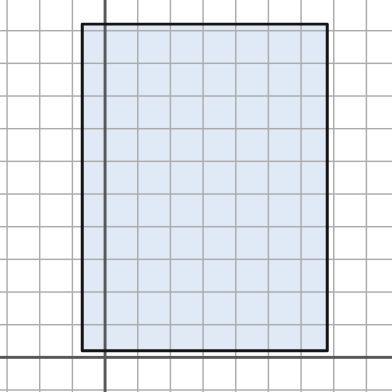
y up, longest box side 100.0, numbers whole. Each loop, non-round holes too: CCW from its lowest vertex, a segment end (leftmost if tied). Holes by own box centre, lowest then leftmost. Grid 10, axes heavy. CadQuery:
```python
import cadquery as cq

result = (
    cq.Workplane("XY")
    .moveTo(-7.0, 2.0)
    .lineTo(68.0, 2.0)
    .lineTo(68.0, 102.0)
    .lineTo(-7.0, 102.0)
    .close()
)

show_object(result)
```